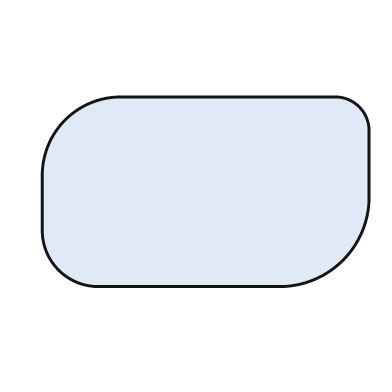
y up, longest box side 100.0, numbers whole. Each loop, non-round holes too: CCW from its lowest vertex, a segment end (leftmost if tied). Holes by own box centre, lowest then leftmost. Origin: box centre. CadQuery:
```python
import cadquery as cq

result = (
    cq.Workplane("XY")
    .moveTo(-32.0, -29.0)
    .lineTo(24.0, -29.0)
    .threePointArc((42.0, -21.0), (50.0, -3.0))
    .lineTo(50.0, 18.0)
    .threePointArc((47.0, 26.0), (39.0, 29.0))
    .lineTo(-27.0, 29.0)
    .threePointArc((-43.0, 22.0), (-50.0, 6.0))
    .lineTo(-50.0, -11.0)
    .threePointArc((-45.0, -24.0), (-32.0, -29.0))
    .close()
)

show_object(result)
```